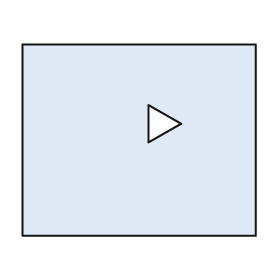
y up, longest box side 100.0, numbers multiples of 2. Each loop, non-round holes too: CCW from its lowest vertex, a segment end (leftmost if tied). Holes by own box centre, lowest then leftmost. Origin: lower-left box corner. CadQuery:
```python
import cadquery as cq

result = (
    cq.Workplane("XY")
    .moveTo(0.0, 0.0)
    .lineTo(100.0, 0.0)
    .lineTo(100.0, 82.0)
    .lineTo(0.0, 82.0)
    .close()
    .moveTo(54.0, 40.0)
    .lineTo(68.0, 48.0)
    .lineTo(54.0, 56.0)
    .close()
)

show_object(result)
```